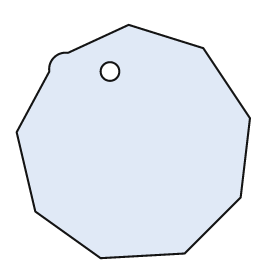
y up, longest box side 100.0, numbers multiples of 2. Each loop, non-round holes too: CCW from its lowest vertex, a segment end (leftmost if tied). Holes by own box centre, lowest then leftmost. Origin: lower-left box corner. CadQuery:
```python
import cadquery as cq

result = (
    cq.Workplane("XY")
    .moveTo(36.0, 0.0)
    .lineTo(72.0, 2.0)
    .lineTo(96.0, 26.0)
    .lineTo(100.0, 60.0)
    .lineTo(80.0, 90.0)
    .lineTo(48.0, 100.0)
    .lineTo(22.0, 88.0)
    .threePointArc((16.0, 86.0), (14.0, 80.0))
    .lineTo(0.0, 54.0)
    .lineTo(8.0, 20.0)
    .close()
    .moveTo(40.0, 80.0)
    .circle(4.0)
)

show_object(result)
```